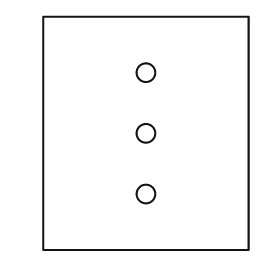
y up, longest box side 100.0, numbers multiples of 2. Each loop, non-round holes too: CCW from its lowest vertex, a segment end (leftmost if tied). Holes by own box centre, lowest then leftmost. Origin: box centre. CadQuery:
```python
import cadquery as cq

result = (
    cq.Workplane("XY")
    .moveTo(-44.0, -50.0)
    .lineTo(44.0, -50.0)
    .lineTo(44.0, 50.0)
    .lineTo(-44.0, 50.0)
    .close()
    .moveTo(0.0, -26.0)
    .circle(4.0)
    .moveTo(0.0, 0.0)
    .circle(4.0)
    .moveTo(0.0, 26.0)
    .circle(4.0)
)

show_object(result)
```